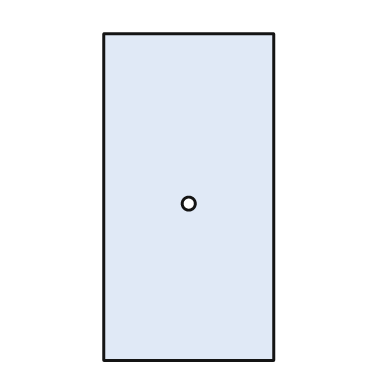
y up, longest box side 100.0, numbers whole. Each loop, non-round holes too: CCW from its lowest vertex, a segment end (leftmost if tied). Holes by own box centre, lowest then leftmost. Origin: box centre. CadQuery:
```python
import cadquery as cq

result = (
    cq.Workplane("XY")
    .moveTo(-26.0, -50.0)
    .lineTo(26.0, -50.0)
    .lineTo(26.0, 50.0)
    .lineTo(-26.0, 50.0)
    .close()
    .moveTo(0.0, -2.0)
    .circle(2.0)
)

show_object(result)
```